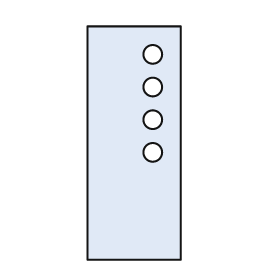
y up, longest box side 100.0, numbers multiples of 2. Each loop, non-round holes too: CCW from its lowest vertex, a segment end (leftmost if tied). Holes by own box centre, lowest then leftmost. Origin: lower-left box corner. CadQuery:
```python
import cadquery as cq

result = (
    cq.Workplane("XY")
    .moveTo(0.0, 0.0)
    .lineTo(40.0, 0.0)
    .lineTo(40.0, 100.0)
    .lineTo(0.0, 100.0)
    .close()
    .moveTo(28.0, 46.0)
    .circle(4.0)
    .moveTo(28.0, 60.0)
    .circle(4.0)
    .moveTo(28.0, 74.0)
    .circle(4.0)
    .moveTo(28.0, 88.0)
    .circle(4.0)
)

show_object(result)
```